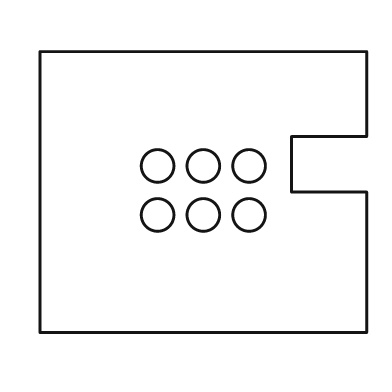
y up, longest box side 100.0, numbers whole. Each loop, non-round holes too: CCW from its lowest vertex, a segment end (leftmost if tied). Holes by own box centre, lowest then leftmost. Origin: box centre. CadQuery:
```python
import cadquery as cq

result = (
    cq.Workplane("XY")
    .moveTo(-50.0, -43.0)
    .lineTo(50.0, -43.0)
    .lineTo(50.0, 0.0)
    .lineTo(27.0, 0.0)
    .lineTo(27.0, 17.0)
    .lineTo(50.0, 17.0)
    .lineTo(50.0, 43.0)
    .lineTo(-50.0, 43.0)
    .close()
    .moveTo(-14.0, -7.0)
    .circle(5.0)
    .moveTo(0.0, -7.0)
    .circle(5.0)
    .moveTo(14.0, -7.0)
    .circle(5.0)
    .moveTo(-14.0, 8.0)
    .circle(5.0)
    .moveTo(0.0, 8.0)
    .circle(5.0)
    .moveTo(14.0, 8.0)
    .circle(5.0)
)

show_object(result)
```